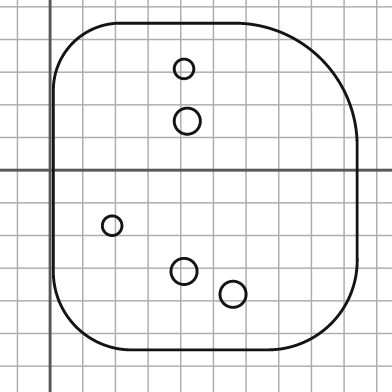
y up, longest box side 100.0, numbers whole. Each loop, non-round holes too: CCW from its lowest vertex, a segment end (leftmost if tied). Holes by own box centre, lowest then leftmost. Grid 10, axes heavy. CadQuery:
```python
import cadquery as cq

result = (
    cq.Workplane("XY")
    .moveTo(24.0, -55.0)
    .lineTo(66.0, -55.0)
    .threePointArc((86.0, -47.0), (94.0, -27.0))
    .lineTo(94.0, 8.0)
    .threePointArc((83.0, 34.0), (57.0, 45.0))
    .lineTo(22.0, 45.0)
    .threePointArc((7.0, 39.0), (1.0, 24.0))
    .lineTo(1.0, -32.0)
    .threePointArc((8.0, -48.0), (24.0, -55.0))
    .close()
    .moveTo(56.0, -38.0)
    .circle(4.0)
    .moveTo(41.0, -31.0)
    .circle(4.0)
    .moveTo(19.0, -17.0)
    .circle(3.0)
    .moveTo(42.0, 15.0)
    .circle(4.0)
    .moveTo(41.0, 31.0)
    .circle(3.0)
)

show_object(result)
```